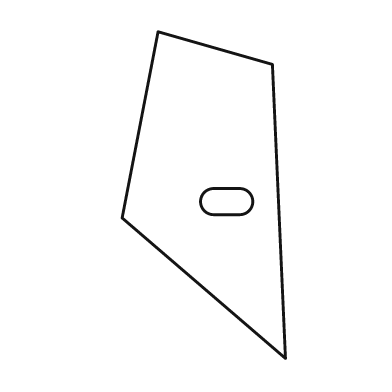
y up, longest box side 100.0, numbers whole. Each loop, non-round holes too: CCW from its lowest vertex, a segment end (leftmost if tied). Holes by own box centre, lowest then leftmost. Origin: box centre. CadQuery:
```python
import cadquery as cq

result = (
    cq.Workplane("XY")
    .moveTo(25.0, -50.0)
    .lineTo(21.0, 40.0)
    .lineTo(-14.0, 50.0)
    .lineTo(-25.0, -7.0)
    .close()
    .moveTo(3.0, -6.0)
    .lineTo(11.0, -6.0)
    .threePointArc((15.0, -2.0), (11.0, 2.0))
    .lineTo(3.0, 2.0)
    .threePointArc((-1.0, -2.0), (3.0, -6.0))
    .close()
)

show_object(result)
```